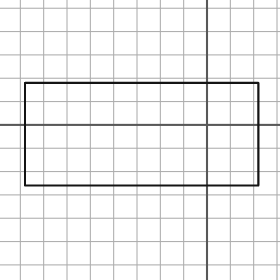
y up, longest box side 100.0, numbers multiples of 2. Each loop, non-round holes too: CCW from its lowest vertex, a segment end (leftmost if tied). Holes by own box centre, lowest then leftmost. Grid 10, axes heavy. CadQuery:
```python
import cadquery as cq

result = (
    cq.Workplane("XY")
    .moveTo(-78.0, -26.0)
    .lineTo(22.0, -26.0)
    .lineTo(22.0, 18.0)
    .lineTo(-78.0, 18.0)
    .close()
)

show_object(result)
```